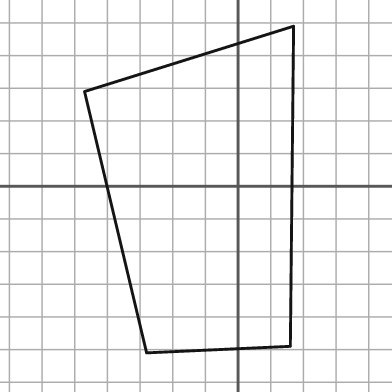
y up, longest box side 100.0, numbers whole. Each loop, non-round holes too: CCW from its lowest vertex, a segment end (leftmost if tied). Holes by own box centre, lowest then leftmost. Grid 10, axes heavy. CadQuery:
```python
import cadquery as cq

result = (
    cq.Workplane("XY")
    .moveTo(-28.0, -51.0)
    .lineTo(16.0, -49.0)
    .lineTo(17.0, 49.0)
    .lineTo(-47.0, 29.0)
    .close()
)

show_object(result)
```